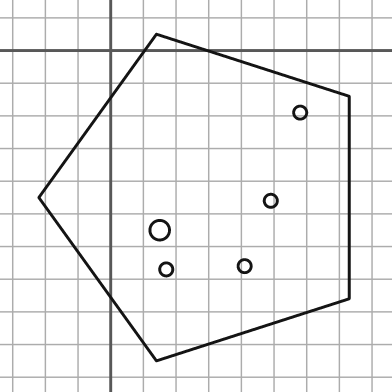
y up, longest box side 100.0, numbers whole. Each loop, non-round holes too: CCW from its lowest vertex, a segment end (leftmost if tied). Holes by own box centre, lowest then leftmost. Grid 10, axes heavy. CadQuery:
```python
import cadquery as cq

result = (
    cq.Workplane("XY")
    .moveTo(14.0, -95.0)
    .lineTo(73.0, -76.0)
    .lineTo(73.0, -14.0)
    .lineTo(14.0, 5.0)
    .lineTo(-22.0, -45.0)
    .close()
    .moveTo(17.0, -67.0)
    .circle(2.0)
    .moveTo(41.0, -66.0)
    .circle(2.0)
    .moveTo(15.0, -55.0)
    .circle(3.0)
    .moveTo(49.0, -46.0)
    .circle(2.0)
    .moveTo(58.0, -19.0)
    .circle(2.0)
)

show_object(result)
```